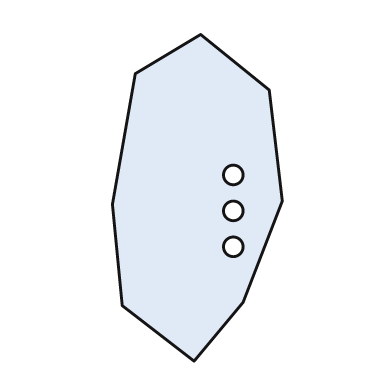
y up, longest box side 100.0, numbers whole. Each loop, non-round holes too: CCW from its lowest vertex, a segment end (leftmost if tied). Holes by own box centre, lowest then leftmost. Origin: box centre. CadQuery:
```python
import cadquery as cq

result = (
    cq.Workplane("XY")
    .moveTo(-1.0, -50.0)
    .lineTo(14.0, -32.0)
    .lineTo(26.0, -1.0)
    .lineTo(22.0, 33.0)
    .lineTo(1.0, 50.0)
    .lineTo(-19.0, 38.0)
    .lineTo(-26.0, -2.0)
    .lineTo(-23.0, -33.0)
    .close()
    .moveTo(11.0, -15.0)
    .circle(3.0)
    .moveTo(11.0, -4.0)
    .circle(3.0)
    .moveTo(11.0, 7.0)
    .circle(3.0)
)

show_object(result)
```